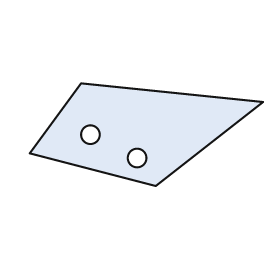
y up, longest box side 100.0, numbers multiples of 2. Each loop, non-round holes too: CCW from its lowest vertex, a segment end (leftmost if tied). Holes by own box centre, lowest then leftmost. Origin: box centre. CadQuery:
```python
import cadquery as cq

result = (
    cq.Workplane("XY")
    .moveTo(4.0, -22.0)
    .lineTo(50.0, 14.0)
    .lineTo(-28.0, 22.0)
    .lineTo(-50.0, -8.0)
    .close()
    .moveTo(-4.0, -10.0)
    .circle(4.0)
    .moveTo(-24.0, 0.0)
    .circle(4.0)
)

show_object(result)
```